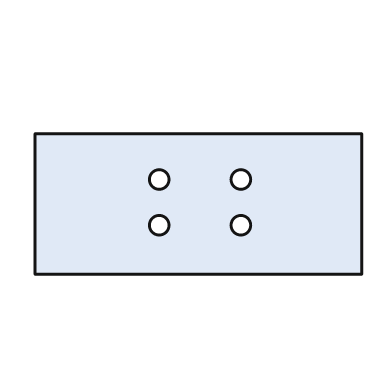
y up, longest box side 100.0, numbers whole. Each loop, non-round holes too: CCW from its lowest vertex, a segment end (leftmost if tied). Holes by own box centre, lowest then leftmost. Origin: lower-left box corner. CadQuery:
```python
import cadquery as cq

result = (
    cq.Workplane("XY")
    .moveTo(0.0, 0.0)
    .lineTo(100.0, 0.0)
    .lineTo(100.0, 43.0)
    .lineTo(0.0, 43.0)
    .close()
    .moveTo(38.0, 15.0)
    .circle(3.0)
    .moveTo(63.0, 15.0)
    .circle(3.0)
    .moveTo(38.0, 29.0)
    .circle(3.0)
    .moveTo(63.0, 29.0)
    .circle(3.0)
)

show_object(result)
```